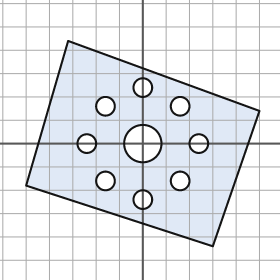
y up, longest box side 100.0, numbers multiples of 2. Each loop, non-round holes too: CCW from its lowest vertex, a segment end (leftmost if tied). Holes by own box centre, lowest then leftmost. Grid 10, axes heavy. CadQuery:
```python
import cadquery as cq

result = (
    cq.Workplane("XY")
    .moveTo(30.0, -44.0)
    .lineTo(50.0, 14.0)
    .lineTo(-32.0, 44.0)
    .lineTo(-50.0, -18.0)
    .close()
    .moveTo(0.0, -24.0)
    .circle(4.0)
    .moveTo(-16.0, -16.0)
    .circle(4.0)
    .moveTo(16.0, -16.0)
    .circle(4.0)
    .moveTo(-24.0, 0.0)
    .circle(4.0)
    .moveTo(0.0, 0.0)
    .circle(8.0)
    .moveTo(24.0, 0.0)
    .circle(4.0)
    .moveTo(-16.0, 16.0)
    .circle(4.0)
    .moveTo(16.0, 16.0)
    .circle(4.0)
    .moveTo(0.0, 24.0)
    .circle(4.0)
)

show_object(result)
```